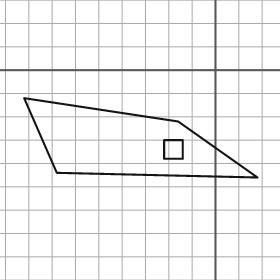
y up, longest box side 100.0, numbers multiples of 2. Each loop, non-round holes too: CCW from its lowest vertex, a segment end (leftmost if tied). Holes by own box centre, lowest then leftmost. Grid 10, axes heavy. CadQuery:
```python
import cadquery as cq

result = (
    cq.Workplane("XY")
    .moveTo(18.0, -46.0)
    .lineTo(-16.0, -22.0)
    .lineTo(-82.0, -12.0)
    .lineTo(-68.0, -44.0)
    .close()
    .moveTo(-22.0, -38.0)
    .lineTo(-14.0, -38.0)
    .lineTo(-14.0, -30.0)
    .lineTo(-22.0, -30.0)
    .close()
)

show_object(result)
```